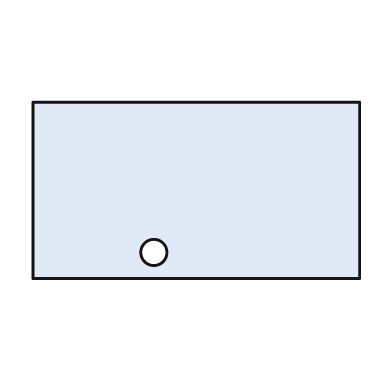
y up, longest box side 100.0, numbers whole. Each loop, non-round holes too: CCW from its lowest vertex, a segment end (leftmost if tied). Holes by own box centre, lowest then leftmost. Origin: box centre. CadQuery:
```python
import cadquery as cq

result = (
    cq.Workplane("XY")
    .moveTo(-50.0, -27.0)
    .lineTo(50.0, -27.0)
    .lineTo(50.0, 27.0)
    .lineTo(-50.0, 27.0)
    .close()
    .moveTo(-13.0, -19.0)
    .circle(4.0)
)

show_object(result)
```